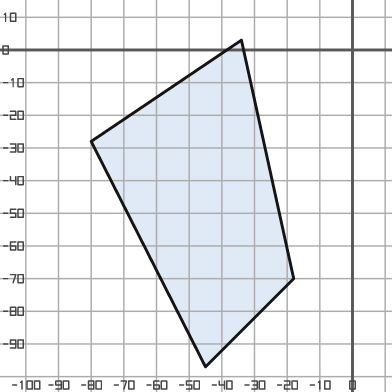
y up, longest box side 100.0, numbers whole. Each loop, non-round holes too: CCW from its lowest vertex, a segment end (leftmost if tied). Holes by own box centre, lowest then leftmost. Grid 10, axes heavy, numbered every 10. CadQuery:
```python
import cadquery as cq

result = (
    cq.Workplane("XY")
    .moveTo(-45.0, -97.0)
    .lineTo(-18.0, -70.0)
    .lineTo(-34.0, 3.0)
    .lineTo(-80.0, -28.0)
    .close()
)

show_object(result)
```